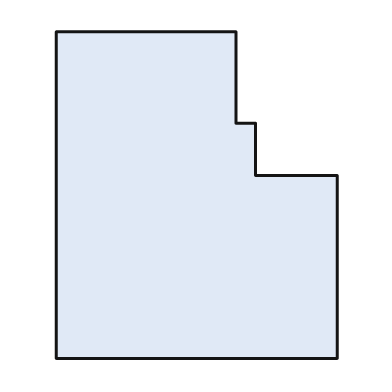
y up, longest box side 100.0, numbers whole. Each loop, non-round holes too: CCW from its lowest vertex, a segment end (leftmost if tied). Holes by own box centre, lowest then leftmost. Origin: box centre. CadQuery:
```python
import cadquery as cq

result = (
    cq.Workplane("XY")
    .moveTo(-43.0, -50.0)
    .lineTo(43.0, -50.0)
    .lineTo(43.0, 6.0)
    .lineTo(18.0, 6.0)
    .lineTo(18.0, 22.0)
    .lineTo(12.0, 22.0)
    .lineTo(12.0, 50.0)
    .lineTo(-43.0, 50.0)
    .close()
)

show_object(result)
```